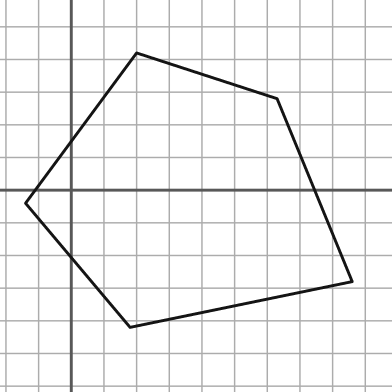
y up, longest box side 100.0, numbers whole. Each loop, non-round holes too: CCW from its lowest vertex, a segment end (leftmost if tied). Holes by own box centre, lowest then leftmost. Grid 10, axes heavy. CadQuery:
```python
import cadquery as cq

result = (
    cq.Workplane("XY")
    .moveTo(18.0, -42.0)
    .lineTo(86.0, -28.0)
    .lineTo(63.0, 28.0)
    .lineTo(20.0, 42.0)
    .lineTo(-14.0, -4.0)
    .close()
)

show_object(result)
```